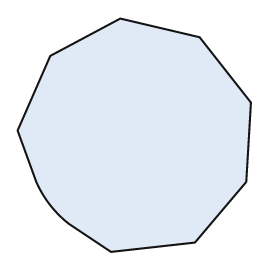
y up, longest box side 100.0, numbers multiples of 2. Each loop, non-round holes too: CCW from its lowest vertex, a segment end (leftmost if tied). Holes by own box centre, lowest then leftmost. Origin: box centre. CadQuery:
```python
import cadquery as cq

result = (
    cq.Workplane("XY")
    .moveTo(-10.0, -50.0)
    .lineTo(26.0, -46.0)
    .lineTo(48.0, -20.0)
    .lineTo(50.0, 14.0)
    .lineTo(28.0, 42.0)
    .lineTo(-6.0, 50.0)
    .lineTo(-36.0, 34.0)
    .lineTo(-50.0, 2.0)
    .lineTo(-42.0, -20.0)
    .threePointArc((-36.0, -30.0), (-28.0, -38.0))
    .close()
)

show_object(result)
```